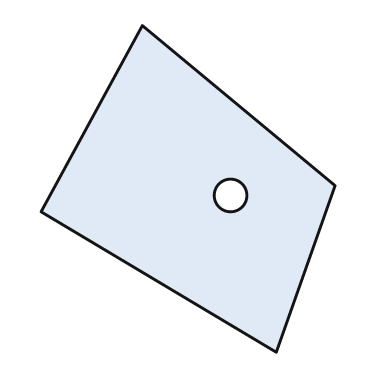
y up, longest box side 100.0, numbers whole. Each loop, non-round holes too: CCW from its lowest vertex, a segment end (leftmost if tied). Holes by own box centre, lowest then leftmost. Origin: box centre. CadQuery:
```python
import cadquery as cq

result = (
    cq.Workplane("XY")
    .moveTo(27.0, -50.0)
    .lineTo(45.0, 1.0)
    .lineTo(-14.0, 50.0)
    .lineTo(-45.0, -7.0)
    .close()
    .moveTo(13.0, -2.0)
    .circle(5.0)
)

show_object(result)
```